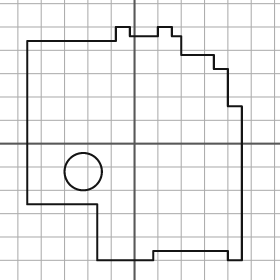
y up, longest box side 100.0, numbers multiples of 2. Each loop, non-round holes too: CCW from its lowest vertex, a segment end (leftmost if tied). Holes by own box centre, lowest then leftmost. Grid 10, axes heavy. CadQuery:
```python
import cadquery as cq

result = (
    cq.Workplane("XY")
    .moveTo(-16.0, -50.0)
    .lineTo(8.0, -50.0)
    .lineTo(8.0, -46.0)
    .lineTo(40.0, -46.0)
    .lineTo(40.0, -50.0)
    .lineTo(46.0, -50.0)
    .lineTo(46.0, 16.0)
    .lineTo(40.0, 16.0)
    .lineTo(40.0, 32.0)
    .lineTo(34.0, 32.0)
    .lineTo(34.0, 38.0)
    .lineTo(20.0, 38.0)
    .lineTo(20.0, 46.0)
    .lineTo(16.0, 46.0)
    .lineTo(16.0, 50.0)
    .lineTo(10.0, 50.0)
    .lineTo(10.0, 46.0)
    .lineTo(-2.0, 46.0)
    .lineTo(-2.0, 50.0)
    .lineTo(-8.0, 50.0)
    .lineTo(-8.0, 44.0)
    .lineTo(-46.0, 44.0)
    .lineTo(-46.0, -26.0)
    .lineTo(-16.0, -26.0)
    .close()
    .moveTo(-22.0, -12.0)
    .circle(8.0)
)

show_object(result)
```